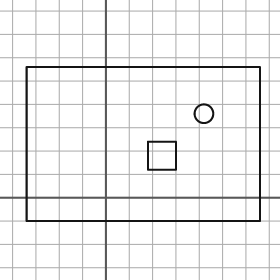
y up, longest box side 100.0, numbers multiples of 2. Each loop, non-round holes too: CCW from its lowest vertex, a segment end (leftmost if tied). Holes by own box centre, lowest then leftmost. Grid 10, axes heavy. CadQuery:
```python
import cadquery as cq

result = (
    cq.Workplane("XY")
    .moveTo(-34.0, -10.0)
    .lineTo(66.0, -10.0)
    .lineTo(66.0, 56.0)
    .lineTo(-34.0, 56.0)
    .close()
    .moveTo(18.0, 12.0)
    .lineTo(30.0, 12.0)
    .lineTo(30.0, 24.0)
    .lineTo(18.0, 24.0)
    .close()
    .moveTo(42.0, 36.0)
    .circle(4.0)
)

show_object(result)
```